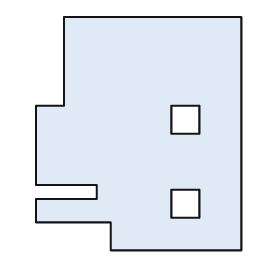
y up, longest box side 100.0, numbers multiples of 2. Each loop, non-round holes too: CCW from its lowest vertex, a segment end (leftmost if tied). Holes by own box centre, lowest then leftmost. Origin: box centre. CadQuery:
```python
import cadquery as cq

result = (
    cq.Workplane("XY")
    .moveTo(-12.0, -50.0)
    .lineTo(44.0, -50.0)
    .lineTo(44.0, 50.0)
    .lineTo(-32.0, 50.0)
    .lineTo(-32.0, 12.0)
    .lineTo(-44.0, 12.0)
    .lineTo(-44.0, -22.0)
    .lineTo(-18.0, -22.0)
    .lineTo(-18.0, -28.0)
    .lineTo(-44.0, -28.0)
    .lineTo(-44.0, -38.0)
    .lineTo(-12.0, -38.0)
    .close()
    .moveTo(14.0, -36.0)
    .lineTo(26.0, -36.0)
    .lineTo(26.0, -24.0)
    .lineTo(14.0, -24.0)
    .close()
    .moveTo(14.0, 0.0)
    .lineTo(26.0, 0.0)
    .lineTo(26.0, 12.0)
    .lineTo(14.0, 12.0)
    .close()
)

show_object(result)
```